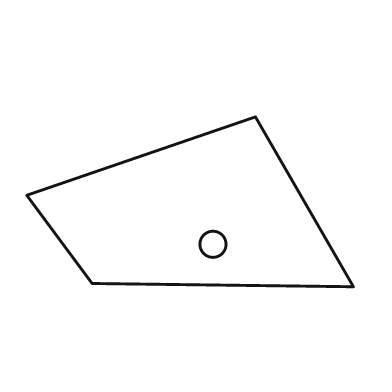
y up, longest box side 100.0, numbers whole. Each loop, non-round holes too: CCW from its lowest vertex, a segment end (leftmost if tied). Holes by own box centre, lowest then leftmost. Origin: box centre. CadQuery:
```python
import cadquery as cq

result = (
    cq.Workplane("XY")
    .moveTo(50.0, -26.0)
    .lineTo(20.0, 26.0)
    .lineTo(-50.0, 2.0)
    .lineTo(-30.0, -25.0)
    .close()
    .moveTo(7.0, -13.0)
    .circle(4.0)
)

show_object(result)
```